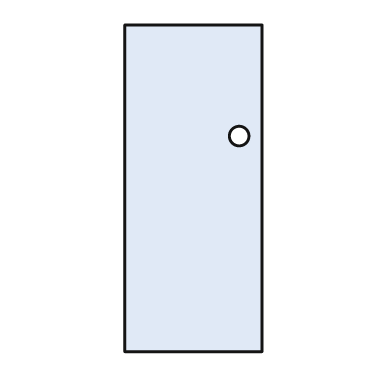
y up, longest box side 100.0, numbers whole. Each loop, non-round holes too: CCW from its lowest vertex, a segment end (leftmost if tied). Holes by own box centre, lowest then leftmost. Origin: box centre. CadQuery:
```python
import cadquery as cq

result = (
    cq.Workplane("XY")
    .moveTo(-21.0, -50.0)
    .lineTo(21.0, -50.0)
    .lineTo(21.0, 50.0)
    .lineTo(-21.0, 50.0)
    .close()
    .moveTo(14.0, 16.0)
    .circle(3.0)
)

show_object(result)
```